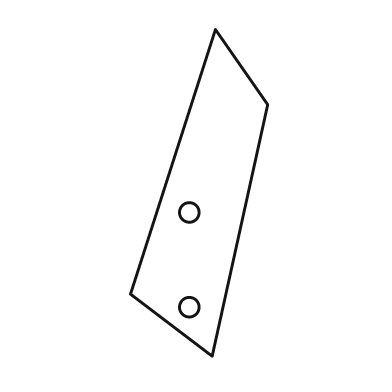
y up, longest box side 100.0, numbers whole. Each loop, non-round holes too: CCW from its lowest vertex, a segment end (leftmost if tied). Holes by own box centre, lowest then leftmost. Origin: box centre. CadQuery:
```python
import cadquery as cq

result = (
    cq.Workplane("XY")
    .moveTo(4.0, -50.0)
    .lineTo(21.0, 27.0)
    .lineTo(5.0, 50.0)
    .lineTo(-21.0, -31.0)
    .close()
    .moveTo(-3.0, -35.0)
    .circle(3.0)
    .moveTo(-3.0, -6.0)
    .circle(3.0)
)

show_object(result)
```